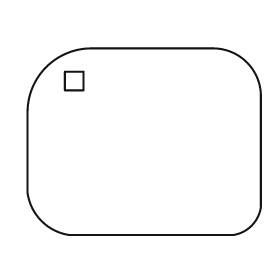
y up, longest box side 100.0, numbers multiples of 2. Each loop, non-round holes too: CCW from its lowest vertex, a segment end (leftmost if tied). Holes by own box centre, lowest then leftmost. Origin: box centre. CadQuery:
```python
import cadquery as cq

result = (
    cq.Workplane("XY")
    .moveTo(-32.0, -40.0)
    .lineTo(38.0, -40.0)
    .threePointArc((46.0, -36.0), (50.0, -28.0))
    .lineTo(50.0, 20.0)
    .threePointArc((44.0, 34.0), (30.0, 40.0))
    .lineTo(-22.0, 40.0)
    .threePointArc((-42.0, 32.0), (-50.0, 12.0))
    .lineTo(-50.0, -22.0)
    .threePointArc((-44.0, -34.0), (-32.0, -40.0))
    .close()
    .moveTo(-34.0, 22.0)
    .lineTo(-26.0, 22.0)
    .lineTo(-26.0, 30.0)
    .lineTo(-34.0, 30.0)
    .close()
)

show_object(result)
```